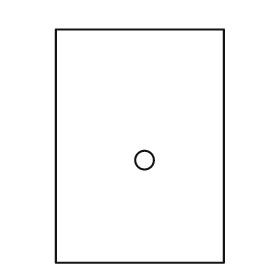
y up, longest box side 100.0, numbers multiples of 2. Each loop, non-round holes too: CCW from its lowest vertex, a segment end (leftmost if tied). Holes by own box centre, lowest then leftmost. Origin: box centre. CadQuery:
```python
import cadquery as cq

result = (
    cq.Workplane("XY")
    .moveTo(-36.0, -50.0)
    .lineTo(36.0, -50.0)
    .lineTo(36.0, 50.0)
    .lineTo(-36.0, 50.0)
    .close()
    .moveTo(2.0, -6.0)
    .circle(4.0)
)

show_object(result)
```